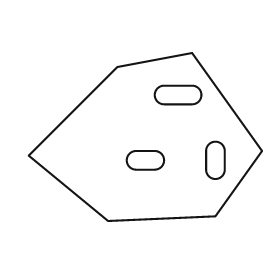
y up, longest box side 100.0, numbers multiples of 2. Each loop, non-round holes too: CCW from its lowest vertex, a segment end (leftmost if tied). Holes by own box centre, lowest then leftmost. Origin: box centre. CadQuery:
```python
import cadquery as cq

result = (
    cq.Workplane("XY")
    .moveTo(-16.0, -36.0)
    .lineTo(30.0, -34.0)
    .lineTo(50.0, -6.0)
    .lineTo(20.0, 36.0)
    .lineTo(-12.0, 30.0)
    .lineTo(-50.0, -8.0)
    .close()
    .moveTo(-4.0, -14.0)
    .lineTo(4.0, -14.0)
    .threePointArc((8.0, -10.0), (4.0, -6.0))
    .lineTo(-4.0, -6.0)
    .threePointArc((-8.0, -10.0), (-4.0, -14.0))
    .close()
    .moveTo(26.0, -14.0)
    .threePointArc((30.0, -18.0), (34.0, -14.0))
    .lineTo(34.0, -6.0)
    .threePointArc((30.0, -2.0), (26.0, -6.0))
    .close()
    .moveTo(8.0, 14.0)
    .lineTo(20.0, 14.0)
    .threePointArc((24.0, 18.0), (20.0, 22.0))
    .lineTo(8.0, 22.0)
    .threePointArc((4.0, 18.0), (8.0, 14.0))
    .close()
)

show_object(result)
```